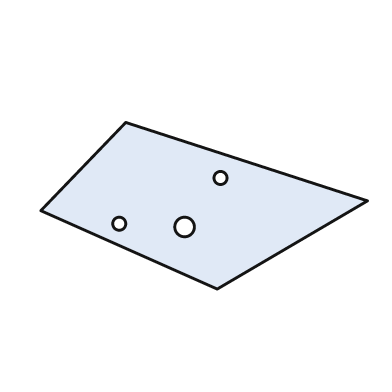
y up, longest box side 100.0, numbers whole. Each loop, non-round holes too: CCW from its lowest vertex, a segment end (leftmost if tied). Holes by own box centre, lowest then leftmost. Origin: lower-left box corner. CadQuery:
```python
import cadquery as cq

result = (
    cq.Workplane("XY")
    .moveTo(54.0, 0.0)
    .lineTo(100.0, 27.0)
    .lineTo(26.0, 51.0)
    .lineTo(0.0, 24.0)
    .close()
    .moveTo(44.0, 19.0)
    .circle(3.0)
    .moveTo(24.0, 20.0)
    .circle(2.0)
    .moveTo(55.0, 34.0)
    .circle(2.0)
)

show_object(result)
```